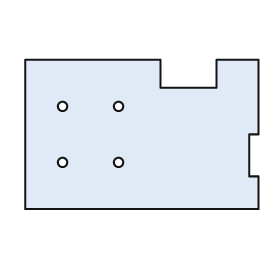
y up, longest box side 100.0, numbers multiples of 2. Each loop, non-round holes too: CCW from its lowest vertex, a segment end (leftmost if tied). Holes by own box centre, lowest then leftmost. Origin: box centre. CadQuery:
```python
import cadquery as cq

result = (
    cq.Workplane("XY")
    .moveTo(-50.0, -32.0)
    .lineTo(50.0, -32.0)
    .lineTo(50.0, -18.0)
    .lineTo(46.0, -18.0)
    .lineTo(46.0, 0.0)
    .lineTo(50.0, 0.0)
    .lineTo(50.0, 32.0)
    .lineTo(32.0, 32.0)
    .lineTo(32.0, 20.0)
    .lineTo(8.0, 20.0)
    .lineTo(8.0, 32.0)
    .lineTo(-50.0, 32.0)
    .close()
    .moveTo(-34.0, -12.0)
    .circle(2.0)
    .moveTo(-10.0, -12.0)
    .circle(2.0)
    .moveTo(-34.0, 12.0)
    .circle(2.0)
    .moveTo(-10.0, 12.0)
    .circle(2.0)
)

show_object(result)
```